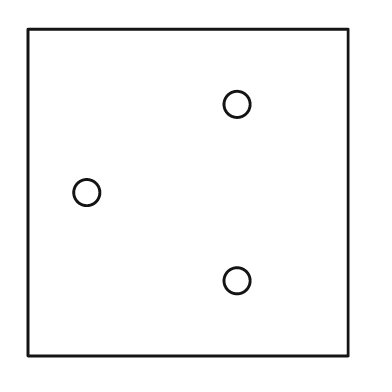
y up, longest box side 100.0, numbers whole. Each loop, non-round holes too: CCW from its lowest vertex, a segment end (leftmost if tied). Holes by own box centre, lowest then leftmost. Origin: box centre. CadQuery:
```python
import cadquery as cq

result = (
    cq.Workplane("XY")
    .moveTo(-49.0, -50.0)
    .lineTo(49.0, -50.0)
    .lineTo(49.0, 50.0)
    .lineTo(-49.0, 50.0)
    .close()
    .moveTo(15.0, -27.0)
    .circle(4.0)
    .moveTo(-31.0, 0.0)
    .circle(4.0)
    .moveTo(15.0, 27.0)
    .circle(4.0)
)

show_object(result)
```